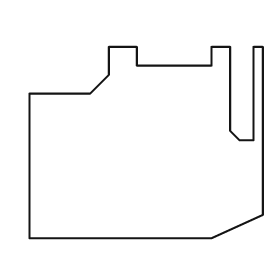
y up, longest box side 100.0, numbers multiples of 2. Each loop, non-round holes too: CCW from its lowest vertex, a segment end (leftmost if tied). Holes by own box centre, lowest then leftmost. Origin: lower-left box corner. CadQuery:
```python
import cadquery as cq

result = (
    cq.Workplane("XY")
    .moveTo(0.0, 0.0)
    .lineTo(78.0, 0.0)
    .lineTo(100.0, 10.0)
    .lineTo(100.0, 82.0)
    .lineTo(96.0, 82.0)
    .lineTo(96.0, 42.0)
    .lineTo(90.0, 42.0)
    .lineTo(86.0, 46.0)
    .lineTo(86.0, 82.0)
    .lineTo(78.0, 82.0)
    .lineTo(78.0, 74.0)
    .lineTo(46.0, 74.0)
    .lineTo(46.0, 82.0)
    .lineTo(34.0, 82.0)
    .lineTo(34.0, 70.0)
    .lineTo(26.0, 62.0)
    .lineTo(0.0, 62.0)
    .close()
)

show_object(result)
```